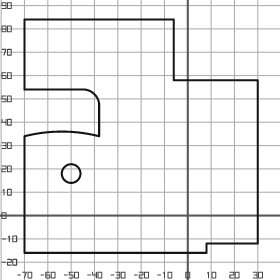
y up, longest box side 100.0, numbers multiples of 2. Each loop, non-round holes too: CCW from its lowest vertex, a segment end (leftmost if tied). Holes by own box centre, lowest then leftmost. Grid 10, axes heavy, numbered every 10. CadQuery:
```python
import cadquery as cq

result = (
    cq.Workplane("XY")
    .moveTo(-70.0, -16.0)
    .lineTo(8.0, -16.0)
    .lineTo(8.0, -12.0)
    .lineTo(30.0, -12.0)
    .lineTo(30.0, 58.0)
    .lineTo(-6.0, 58.0)
    .lineTo(-6.0, 84.0)
    .lineTo(-70.0, 84.0)
    .lineTo(-70.0, 54.0)
    .lineTo(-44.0, 54.0)
    .threePointArc((-40.0, 52.0), (-38.0, 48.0))
    .lineTo(-38.0, 34.0)
    .threePointArc((-54.0, 36.0), (-70.0, 34.0))
    .close()
    .moveTo(-50.0, 18.0)
    .circle(4.0)
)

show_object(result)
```